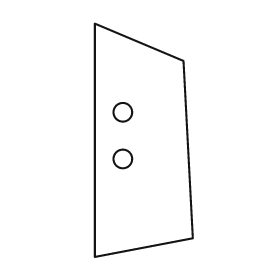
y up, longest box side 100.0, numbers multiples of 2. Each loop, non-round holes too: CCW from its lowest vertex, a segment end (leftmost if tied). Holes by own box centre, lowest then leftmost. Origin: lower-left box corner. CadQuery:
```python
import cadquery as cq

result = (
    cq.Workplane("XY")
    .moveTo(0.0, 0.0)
    .lineTo(42.0, 8.0)
    .lineTo(38.0, 84.0)
    .lineTo(0.0, 100.0)
    .close()
    .moveTo(12.0, 42.0)
    .circle(4.0)
    .moveTo(12.0, 62.0)
    .circle(4.0)
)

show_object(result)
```